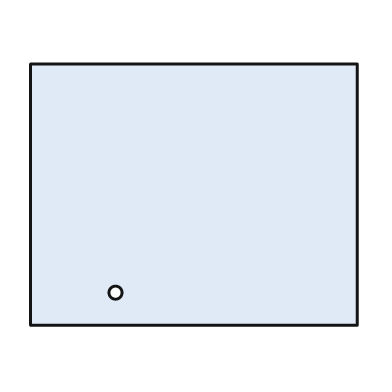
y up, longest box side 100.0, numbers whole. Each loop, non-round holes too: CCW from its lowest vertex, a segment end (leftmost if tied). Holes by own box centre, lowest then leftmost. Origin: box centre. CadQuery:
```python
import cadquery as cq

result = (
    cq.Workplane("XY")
    .moveTo(-50.0, -40.0)
    .lineTo(50.0, -40.0)
    .lineTo(50.0, 40.0)
    .lineTo(-50.0, 40.0)
    .close()
    .moveTo(-24.0, -30.0)
    .circle(2.0)
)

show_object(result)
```